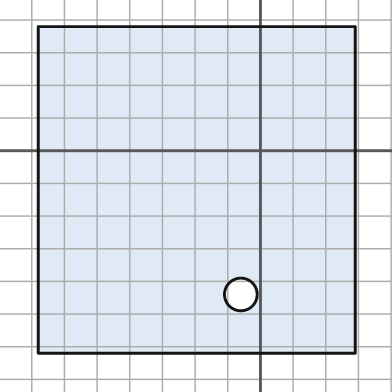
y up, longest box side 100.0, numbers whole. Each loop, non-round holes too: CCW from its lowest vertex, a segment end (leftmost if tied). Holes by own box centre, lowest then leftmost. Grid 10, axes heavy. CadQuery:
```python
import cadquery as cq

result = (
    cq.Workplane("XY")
    .moveTo(-68.0, -62.0)
    .lineTo(29.0, -62.0)
    .lineTo(29.0, 38.0)
    .lineTo(-68.0, 38.0)
    .close()
    .moveTo(-6.0, -44.0)
    .circle(5.0)
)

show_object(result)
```